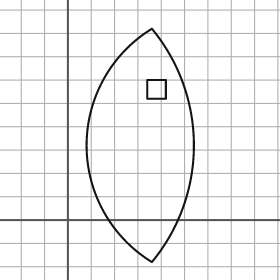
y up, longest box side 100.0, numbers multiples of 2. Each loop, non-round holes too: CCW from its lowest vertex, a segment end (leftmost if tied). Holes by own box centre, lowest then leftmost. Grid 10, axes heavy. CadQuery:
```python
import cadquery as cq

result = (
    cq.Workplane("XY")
    .moveTo(36.0, -18.0)
    .threePointArc((54.0, 32.0), (36.0, 82.0))
    .threePointArc((8.0, 32.0), (36.0, -18.0))
    .close()
    .moveTo(34.0, 52.0)
    .lineTo(42.0, 52.0)
    .lineTo(42.0, 60.0)
    .lineTo(34.0, 60.0)
    .close()
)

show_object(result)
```